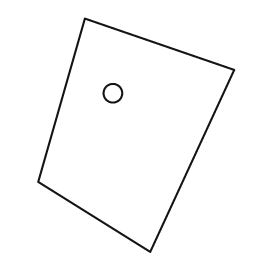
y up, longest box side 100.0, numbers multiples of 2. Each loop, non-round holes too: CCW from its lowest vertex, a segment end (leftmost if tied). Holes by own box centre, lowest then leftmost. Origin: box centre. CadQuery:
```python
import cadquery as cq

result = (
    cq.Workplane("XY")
    .moveTo(6.0, -50.0)
    .lineTo(42.0, 28.0)
    .lineTo(-22.0, 50.0)
    .lineTo(-42.0, -20.0)
    .close()
    .moveTo(-10.0, 18.0)
    .circle(4.0)
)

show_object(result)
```